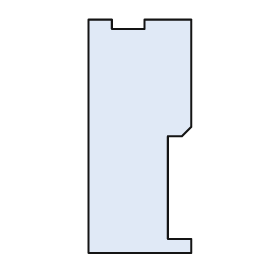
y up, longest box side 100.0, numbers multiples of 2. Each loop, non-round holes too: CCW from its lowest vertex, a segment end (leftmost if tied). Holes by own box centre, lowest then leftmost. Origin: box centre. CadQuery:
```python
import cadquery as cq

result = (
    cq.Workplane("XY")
    .moveTo(-22.0, -50.0)
    .lineTo(22.0, -50.0)
    .lineTo(22.0, -44.0)
    .lineTo(12.0, -44.0)
    .lineTo(12.0, 0.0)
    .lineTo(18.0, 0.0)
    .lineTo(22.0, 4.0)
    .lineTo(22.0, 50.0)
    .lineTo(2.0, 50.0)
    .lineTo(2.0, 46.0)
    .lineTo(-12.0, 46.0)
    .lineTo(-12.0, 50.0)
    .lineTo(-22.0, 50.0)
    .close()
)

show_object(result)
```